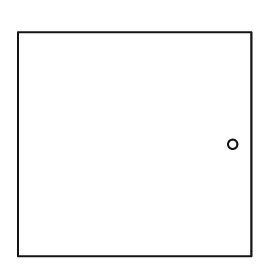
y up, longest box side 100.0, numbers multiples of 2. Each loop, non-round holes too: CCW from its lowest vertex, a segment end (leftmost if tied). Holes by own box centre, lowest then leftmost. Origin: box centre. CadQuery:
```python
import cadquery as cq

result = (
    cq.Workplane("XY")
    .moveTo(-50.0, -48.0)
    .lineTo(50.0, -48.0)
    .lineTo(50.0, 48.0)
    .lineTo(-50.0, 48.0)
    .close()
    .moveTo(42.0, 0.0)
    .circle(2.0)
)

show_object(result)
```